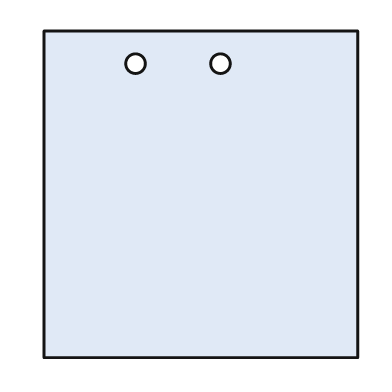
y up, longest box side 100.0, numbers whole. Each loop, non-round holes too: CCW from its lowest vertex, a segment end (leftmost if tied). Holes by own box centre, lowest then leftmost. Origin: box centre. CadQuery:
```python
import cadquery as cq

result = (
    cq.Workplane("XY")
    .moveTo(-48.0, -50.0)
    .lineTo(48.0, -50.0)
    .lineTo(48.0, 50.0)
    .lineTo(-48.0, 50.0)
    .close()
    .moveTo(-20.0, 40.0)
    .circle(3.0)
    .moveTo(6.0, 40.0)
    .circle(3.0)
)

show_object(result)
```